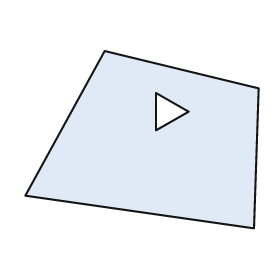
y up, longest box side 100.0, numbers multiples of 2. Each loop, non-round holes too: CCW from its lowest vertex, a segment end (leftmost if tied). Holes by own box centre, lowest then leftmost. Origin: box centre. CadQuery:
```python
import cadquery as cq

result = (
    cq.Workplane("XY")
    .moveTo(48.0, -38.0)
    .lineTo(50.0, 22.0)
    .lineTo(-16.0, 38.0)
    .lineTo(-50.0, -24.0)
    .close()
    .moveTo(6.0, 4.0)
    .lineTo(20.0, 12.0)
    .lineTo(6.0, 20.0)
    .close()
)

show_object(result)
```